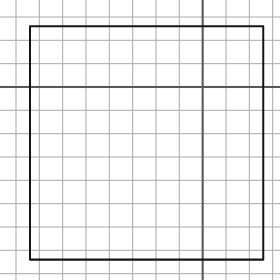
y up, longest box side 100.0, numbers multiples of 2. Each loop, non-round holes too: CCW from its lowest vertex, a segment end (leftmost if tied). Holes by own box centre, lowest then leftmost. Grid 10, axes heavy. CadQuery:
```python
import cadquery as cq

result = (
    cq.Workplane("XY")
    .moveTo(-74.0, -74.0)
    .lineTo(26.0, -74.0)
    .lineTo(26.0, 26.0)
    .lineTo(-74.0, 26.0)
    .close()
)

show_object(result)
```